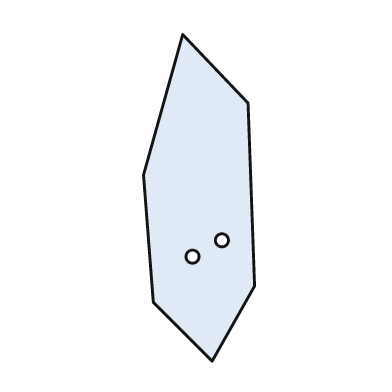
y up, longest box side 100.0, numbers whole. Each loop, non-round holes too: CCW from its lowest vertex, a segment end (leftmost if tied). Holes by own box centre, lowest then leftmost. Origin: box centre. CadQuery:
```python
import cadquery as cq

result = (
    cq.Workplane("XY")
    .moveTo(4.0, -50.0)
    .lineTo(17.0, -27.0)
    .lineTo(15.0, 29.0)
    .lineTo(-5.0, 50.0)
    .lineTo(-17.0, 7.0)
    .lineTo(-14.0, -32.0)
    .close()
    .moveTo(-2.0, -18.0)
    .circle(2.0)
    .moveTo(7.0, -13.0)
    .circle(2.0)
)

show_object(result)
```